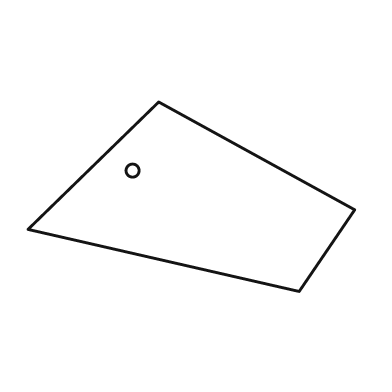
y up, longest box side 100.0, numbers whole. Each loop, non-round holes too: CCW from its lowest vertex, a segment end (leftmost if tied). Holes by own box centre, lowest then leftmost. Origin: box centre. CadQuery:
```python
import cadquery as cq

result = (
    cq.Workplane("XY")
    .moveTo(33.0, -29.0)
    .lineTo(50.0, -4.0)
    .lineTo(-10.0, 29.0)
    .lineTo(-50.0, -10.0)
    .close()
    .moveTo(-18.0, 8.0)
    .circle(2.0)
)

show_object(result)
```